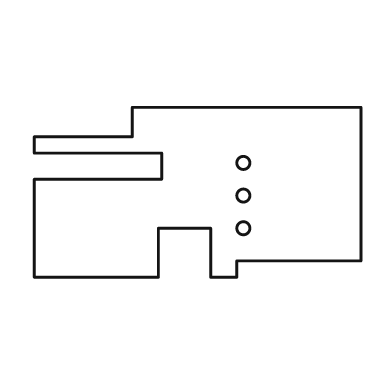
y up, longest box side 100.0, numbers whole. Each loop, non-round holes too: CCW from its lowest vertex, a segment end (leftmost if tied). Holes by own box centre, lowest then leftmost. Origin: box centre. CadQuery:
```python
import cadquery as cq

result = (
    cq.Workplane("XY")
    .moveTo(-50.0, -26.0)
    .lineTo(-12.0, -26.0)
    .lineTo(-12.0, -11.0)
    .lineTo(4.0, -11.0)
    .lineTo(4.0, -26.0)
    .lineTo(12.0, -26.0)
    .lineTo(12.0, -21.0)
    .lineTo(50.0, -21.0)
    .lineTo(50.0, 26.0)
    .lineTo(-20.0, 26.0)
    .lineTo(-20.0, 17.0)
    .lineTo(-50.0, 17.0)
    .lineTo(-50.0, 12.0)
    .lineTo(-11.0, 12.0)
    .lineTo(-11.0, 4.0)
    .lineTo(-50.0, 4.0)
    .close()
    .moveTo(14.0, -11.0)
    .circle(2.0)
    .moveTo(14.0, -1.0)
    .circle(2.0)
    .moveTo(14.0, 9.0)
    .circle(2.0)
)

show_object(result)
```